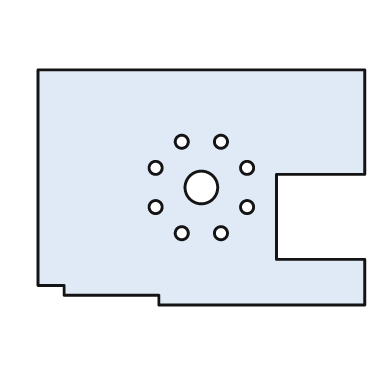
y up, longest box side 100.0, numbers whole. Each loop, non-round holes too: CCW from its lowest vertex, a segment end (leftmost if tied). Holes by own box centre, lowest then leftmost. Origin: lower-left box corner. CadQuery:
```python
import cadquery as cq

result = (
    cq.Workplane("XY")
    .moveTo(37.0, 0.0)
    .lineTo(100.0, 0.0)
    .lineTo(100.0, 14.0)
    .lineTo(73.0, 14.0)
    .lineTo(73.0, 40.0)
    .lineTo(100.0, 40.0)
    .lineTo(100.0, 72.0)
    .lineTo(0.0, 72.0)
    .lineTo(0.0, 6.0)
    .lineTo(8.0, 6.0)
    .lineTo(8.0, 3.0)
    .lineTo(37.0, 3.0)
    .close()
    .moveTo(44.0, 22.0)
    .circle(2.0)
    .moveTo(56.0, 22.0)
    .circle(2.0)
    .moveTo(36.0, 30.0)
    .circle(2.0)
    .moveTo(64.0, 30.0)
    .circle(2.0)
    .moveTo(50.0, 36.0)
    .circle(5.0)
    .moveTo(36.0, 42.0)
    .circle(2.0)
    .moveTo(64.0, 42.0)
    .circle(2.0)
    .moveTo(44.0, 50.0)
    .circle(2.0)
    .moveTo(56.0, 50.0)
    .circle(2.0)
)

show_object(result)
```